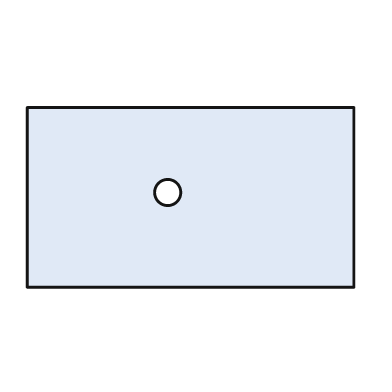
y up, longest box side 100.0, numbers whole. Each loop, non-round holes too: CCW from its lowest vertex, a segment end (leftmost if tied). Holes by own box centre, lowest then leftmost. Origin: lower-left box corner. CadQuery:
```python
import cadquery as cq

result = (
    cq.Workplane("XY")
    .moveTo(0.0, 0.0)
    .lineTo(100.0, 0.0)
    .lineTo(100.0, 55.0)
    .lineTo(0.0, 55.0)
    .close()
    .moveTo(43.0, 29.0)
    .circle(4.0)
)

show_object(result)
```